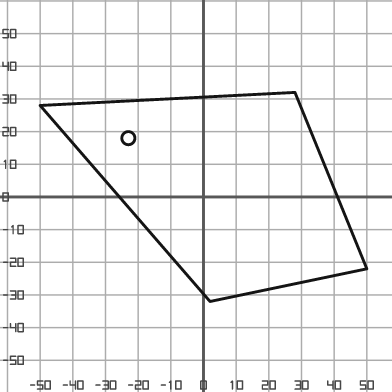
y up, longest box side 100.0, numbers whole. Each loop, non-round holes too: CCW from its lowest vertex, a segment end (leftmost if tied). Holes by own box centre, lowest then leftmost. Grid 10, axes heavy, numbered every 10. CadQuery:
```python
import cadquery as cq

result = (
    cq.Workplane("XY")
    .moveTo(2.0, -32.0)
    .lineTo(50.0, -22.0)
    .lineTo(28.0, 32.0)
    .lineTo(-50.0, 28.0)
    .close()
    .moveTo(-23.0, 18.0)
    .circle(2.0)
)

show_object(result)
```